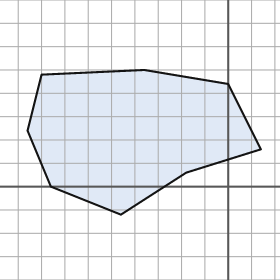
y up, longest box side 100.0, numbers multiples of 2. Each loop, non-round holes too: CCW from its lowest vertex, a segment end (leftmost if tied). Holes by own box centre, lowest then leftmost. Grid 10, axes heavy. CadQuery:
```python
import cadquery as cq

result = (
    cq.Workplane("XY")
    .moveTo(-46.0, -12.0)
    .lineTo(-18.0, 6.0)
    .lineTo(14.0, 16.0)
    .lineTo(0.0, 44.0)
    .lineTo(-36.0, 50.0)
    .lineTo(-80.0, 48.0)
    .lineTo(-86.0, 24.0)
    .lineTo(-76.0, 0.0)
    .close()
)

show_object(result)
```